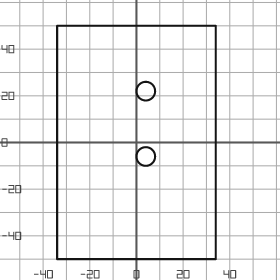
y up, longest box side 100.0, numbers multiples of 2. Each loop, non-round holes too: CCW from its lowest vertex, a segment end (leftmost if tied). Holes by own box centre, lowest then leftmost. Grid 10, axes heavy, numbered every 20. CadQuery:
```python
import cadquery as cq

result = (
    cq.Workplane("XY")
    .moveTo(-34.0, -50.0)
    .lineTo(34.0, -50.0)
    .lineTo(34.0, 50.0)
    .lineTo(-34.0, 50.0)
    .close()
    .moveTo(4.0, -6.0)
    .circle(4.0)
    .moveTo(4.0, 22.0)
    .circle(4.0)
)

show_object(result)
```